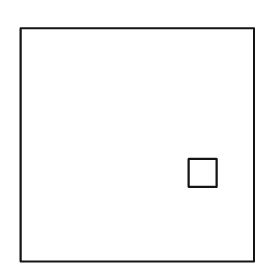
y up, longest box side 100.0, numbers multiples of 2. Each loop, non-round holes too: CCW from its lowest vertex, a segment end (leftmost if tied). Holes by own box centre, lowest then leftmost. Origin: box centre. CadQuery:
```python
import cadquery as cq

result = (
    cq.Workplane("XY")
    .moveTo(-50.0, -50.0)
    .lineTo(50.0, -50.0)
    .lineTo(50.0, 50.0)
    .lineTo(-50.0, 50.0)
    .close()
    .moveTo(22.0, -18.0)
    .lineTo(34.0, -18.0)
    .lineTo(34.0, -6.0)
    .lineTo(22.0, -6.0)
    .close()
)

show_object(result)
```